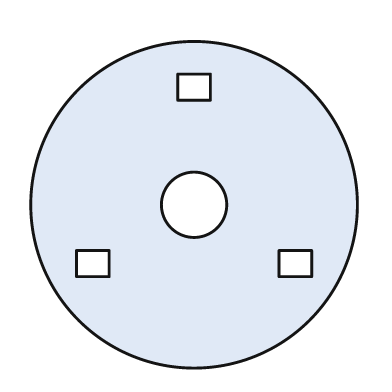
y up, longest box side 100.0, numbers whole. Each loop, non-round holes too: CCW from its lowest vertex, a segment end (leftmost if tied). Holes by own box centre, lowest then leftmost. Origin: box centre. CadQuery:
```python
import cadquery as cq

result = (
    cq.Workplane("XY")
    .moveTo(0.0, 0.0)
    .circle(50.0)
    .moveTo(-36.0, -22.0)
    .lineTo(-26.0, -22.0)
    .lineTo(-26.0, -14.0)
    .lineTo(-36.0, -14.0)
    .close()
    .moveTo(26.0, -22.0)
    .lineTo(36.0, -22.0)
    .lineTo(36.0, -14.0)
    .lineTo(26.0, -14.0)
    .close()
    .moveTo(0.0, 0.0)
    .circle(10.0)
    .moveTo(-5.0, 32.0)
    .lineTo(5.0, 32.0)
    .lineTo(5.0, 40.0)
    .lineTo(-5.0, 40.0)
    .close()
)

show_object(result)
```